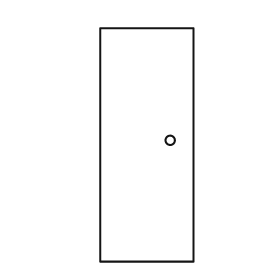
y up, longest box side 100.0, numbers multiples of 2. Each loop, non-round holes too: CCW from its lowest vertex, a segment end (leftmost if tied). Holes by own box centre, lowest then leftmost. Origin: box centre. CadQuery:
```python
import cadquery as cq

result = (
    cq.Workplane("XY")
    .moveTo(-20.0, -50.0)
    .lineTo(20.0, -50.0)
    .lineTo(20.0, 50.0)
    .lineTo(-20.0, 50.0)
    .close()
    .moveTo(10.0, 2.0)
    .circle(2.0)
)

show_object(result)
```